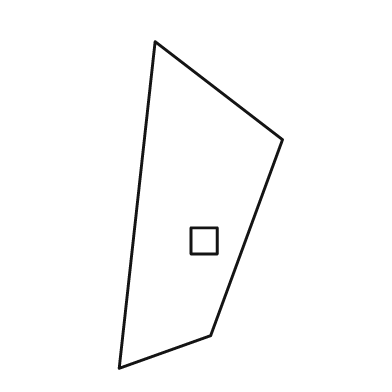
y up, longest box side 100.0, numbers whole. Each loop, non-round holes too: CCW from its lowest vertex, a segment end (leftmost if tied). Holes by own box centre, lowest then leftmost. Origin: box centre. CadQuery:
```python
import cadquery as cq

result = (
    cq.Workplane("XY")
    .moveTo(-25.0, -50.0)
    .lineTo(3.0, -40.0)
    .lineTo(25.0, 20.0)
    .lineTo(-14.0, 50.0)
    .close()
    .moveTo(-3.0, -15.0)
    .lineTo(5.0, -15.0)
    .lineTo(5.0, -7.0)
    .lineTo(-3.0, -7.0)
    .close()
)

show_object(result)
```